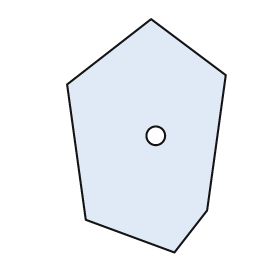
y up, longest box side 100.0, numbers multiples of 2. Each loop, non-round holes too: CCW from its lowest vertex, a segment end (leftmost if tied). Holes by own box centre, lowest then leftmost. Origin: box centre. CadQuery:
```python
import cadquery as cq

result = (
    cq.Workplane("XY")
    .moveTo(12.0, -50.0)
    .lineTo(26.0, -32.0)
    .lineTo(34.0, 26.0)
    .lineTo(2.0, 50.0)
    .lineTo(-34.0, 22.0)
    .lineTo(-26.0, -36.0)
    .close()
    .moveTo(4.0, 0.0)
    .circle(4.0)
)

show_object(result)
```